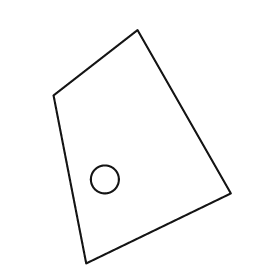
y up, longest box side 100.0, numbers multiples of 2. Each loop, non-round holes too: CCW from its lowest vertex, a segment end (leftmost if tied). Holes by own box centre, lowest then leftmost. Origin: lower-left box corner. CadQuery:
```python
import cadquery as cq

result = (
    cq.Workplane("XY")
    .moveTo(14.0, 0.0)
    .lineTo(76.0, 30.0)
    .lineTo(36.0, 100.0)
    .lineTo(0.0, 72.0)
    .close()
    .moveTo(22.0, 36.0)
    .circle(6.0)
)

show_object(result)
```